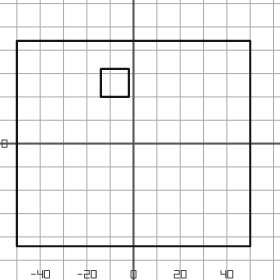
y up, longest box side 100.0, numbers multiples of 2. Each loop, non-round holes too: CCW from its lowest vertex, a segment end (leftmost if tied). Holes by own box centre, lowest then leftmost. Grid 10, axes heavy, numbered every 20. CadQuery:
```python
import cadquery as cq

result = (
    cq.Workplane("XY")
    .moveTo(-50.0, -44.0)
    .lineTo(50.0, -44.0)
    .lineTo(50.0, 44.0)
    .lineTo(-50.0, 44.0)
    .close()
    .moveTo(-14.0, 20.0)
    .lineTo(-2.0, 20.0)
    .lineTo(-2.0, 32.0)
    .lineTo(-14.0, 32.0)
    .close()
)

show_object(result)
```